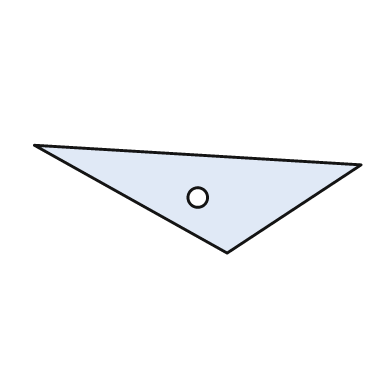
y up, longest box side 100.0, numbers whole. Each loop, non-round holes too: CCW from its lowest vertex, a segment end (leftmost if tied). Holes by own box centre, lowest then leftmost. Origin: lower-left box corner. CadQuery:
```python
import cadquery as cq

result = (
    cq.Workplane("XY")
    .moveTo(59.0, 0.0)
    .lineTo(100.0, 27.0)
    .lineTo(0.0, 33.0)
    .close()
    .moveTo(50.0, 17.0)
    .circle(3.0)
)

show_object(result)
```